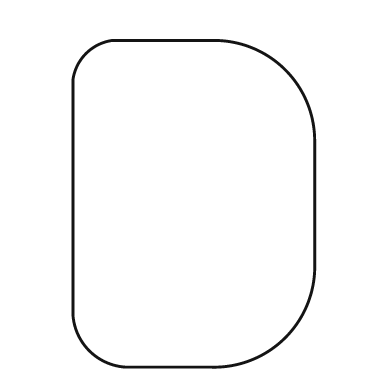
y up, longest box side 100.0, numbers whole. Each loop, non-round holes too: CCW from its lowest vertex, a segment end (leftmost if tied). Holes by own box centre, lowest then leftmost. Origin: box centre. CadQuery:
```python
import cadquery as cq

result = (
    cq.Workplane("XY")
    .moveTo(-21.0, -50.0)
    .lineTo(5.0, -50.0)
    .threePointArc((28.0, -41.0), (37.0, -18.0))
    .lineTo(37.0, 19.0)
    .threePointArc((28.0, 41.0), (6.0, 50.0))
    .lineTo(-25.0, 50.0)
    .threePointArc((-33.0, 46.0), (-37.0, 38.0))
    .lineTo(-37.0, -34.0)
    .threePointArc((-32.0, -45.0), (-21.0, -50.0))
    .close()
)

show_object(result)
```